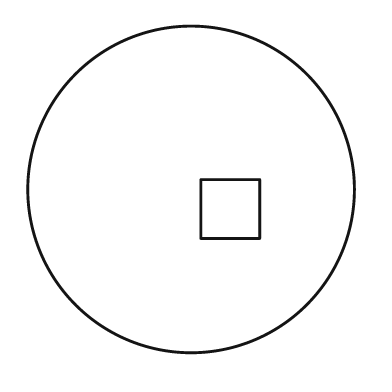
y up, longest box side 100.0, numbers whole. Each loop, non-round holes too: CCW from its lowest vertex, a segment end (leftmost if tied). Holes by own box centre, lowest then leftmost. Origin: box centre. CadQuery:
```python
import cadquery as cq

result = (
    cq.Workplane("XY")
    .moveTo(0.0, 0.0)
    .circle(50.0)
    .moveTo(3.0, -15.0)
    .lineTo(21.0, -15.0)
    .lineTo(21.0, 3.0)
    .lineTo(3.0, 3.0)
    .close()
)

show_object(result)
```